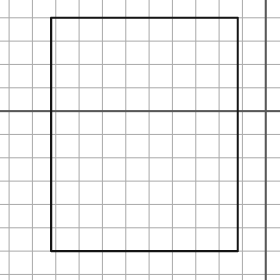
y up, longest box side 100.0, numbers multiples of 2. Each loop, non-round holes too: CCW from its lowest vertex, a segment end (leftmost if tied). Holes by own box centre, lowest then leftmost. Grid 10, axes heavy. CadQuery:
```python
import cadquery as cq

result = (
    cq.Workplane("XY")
    .moveTo(-92.0, -60.0)
    .lineTo(-12.0, -60.0)
    .lineTo(-12.0, 40.0)
    .lineTo(-92.0, 40.0)
    .close()
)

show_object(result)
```